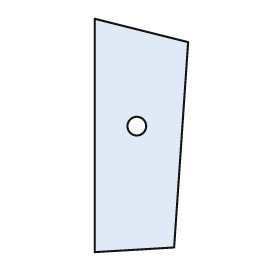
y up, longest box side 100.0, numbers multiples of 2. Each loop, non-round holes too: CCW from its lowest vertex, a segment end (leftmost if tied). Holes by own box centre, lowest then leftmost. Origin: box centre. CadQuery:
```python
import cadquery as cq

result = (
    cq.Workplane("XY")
    .moveTo(-20.0, -50.0)
    .lineTo(14.0, -48.0)
    .lineTo(20.0, 40.0)
    .lineTo(-20.0, 50.0)
    .close()
    .moveTo(-2.0, 4.0)
    .circle(4.0)
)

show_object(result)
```